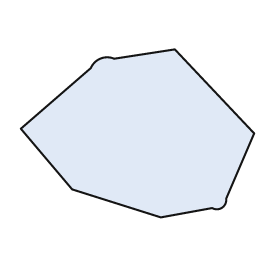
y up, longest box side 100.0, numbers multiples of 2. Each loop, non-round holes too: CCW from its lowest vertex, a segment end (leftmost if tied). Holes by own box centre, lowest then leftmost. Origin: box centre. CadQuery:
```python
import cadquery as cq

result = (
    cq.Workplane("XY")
    .moveTo(10.0, -36.0)
    .lineTo(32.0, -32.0)
    .threePointArc((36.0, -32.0), (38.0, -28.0))
    .lineTo(50.0, 0.0)
    .lineTo(16.0, 36.0)
    .lineTo(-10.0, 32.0)
    .threePointArc((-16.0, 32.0), (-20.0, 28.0))
    .lineTo(-50.0, 2.0)
    .lineTo(-28.0, -24.0)
    .close()
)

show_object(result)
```